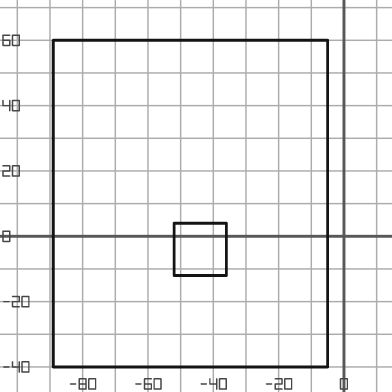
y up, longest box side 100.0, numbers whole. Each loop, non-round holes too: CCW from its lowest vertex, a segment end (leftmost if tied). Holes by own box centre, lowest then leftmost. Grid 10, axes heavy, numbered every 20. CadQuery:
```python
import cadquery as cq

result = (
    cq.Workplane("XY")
    .moveTo(-89.0, -40.0)
    .lineTo(-5.0, -40.0)
    .lineTo(-5.0, 60.0)
    .lineTo(-89.0, 60.0)
    .close()
    .moveTo(-52.0, -12.0)
    .lineTo(-36.0, -12.0)
    .lineTo(-36.0, 4.0)
    .lineTo(-52.0, 4.0)
    .close()
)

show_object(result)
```